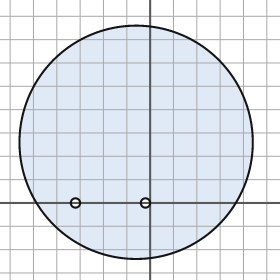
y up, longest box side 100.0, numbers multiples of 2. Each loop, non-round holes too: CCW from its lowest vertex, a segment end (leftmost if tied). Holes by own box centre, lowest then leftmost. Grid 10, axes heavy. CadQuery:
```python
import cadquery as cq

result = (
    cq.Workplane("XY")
    .moveTo(-6.0, 26.0)
    .circle(50.0)
    .moveTo(-32.0, 0.0)
    .circle(2.0)
    .moveTo(-2.0, 0.0)
    .circle(2.0)
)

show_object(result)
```